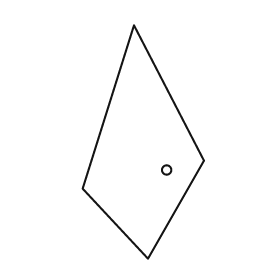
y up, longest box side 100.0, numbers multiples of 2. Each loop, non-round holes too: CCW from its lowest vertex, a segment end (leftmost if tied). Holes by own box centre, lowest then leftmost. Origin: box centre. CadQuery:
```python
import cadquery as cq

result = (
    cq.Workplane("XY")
    .moveTo(2.0, -50.0)
    .lineTo(26.0, -8.0)
    .lineTo(-4.0, 50.0)
    .lineTo(-26.0, -20.0)
    .close()
    .moveTo(10.0, -12.0)
    .circle(2.0)
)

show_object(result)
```